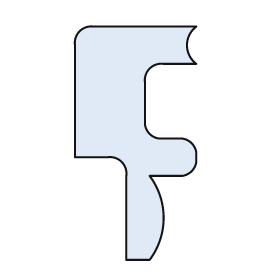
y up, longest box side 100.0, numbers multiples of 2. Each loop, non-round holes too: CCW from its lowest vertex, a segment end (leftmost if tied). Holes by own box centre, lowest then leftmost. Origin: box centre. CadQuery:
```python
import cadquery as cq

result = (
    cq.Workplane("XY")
    .moveTo(-4.0, -50.0)
    .lineTo(6.0, -50.0)
    .threePointArc((12.0, -32.0), (6.0, -14.0))
    .lineTo(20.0, -14.0)
    .threePointArc((24.0, -12.0), (26.0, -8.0))
    .lineTo(26.0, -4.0)
    .threePointArc((24.0, 0.0), (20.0, 2.0))
    .lineTo(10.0, 2.0)
    .threePointArc((6.0, 4.0), (4.0, 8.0))
    .lineTo(4.0, 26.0)
    .threePointArc((6.0, 32.0), (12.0, 34.0))
    .lineTo(26.0, 34.0)
    .threePointArc((22.0, 42.0), (26.0, 50.0))
    .lineTo(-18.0, 50.0)
    .threePointArc((-24.0, 48.0), (-26.0, 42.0))
    .lineTo(-26.0, -6.0)
    .lineTo(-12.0, -6.0)
    .threePointArc((-6.0, -8.0), (-4.0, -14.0))
    .close()
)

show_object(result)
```